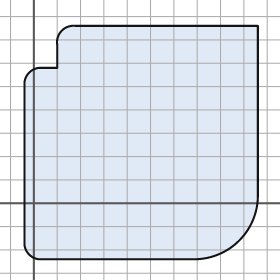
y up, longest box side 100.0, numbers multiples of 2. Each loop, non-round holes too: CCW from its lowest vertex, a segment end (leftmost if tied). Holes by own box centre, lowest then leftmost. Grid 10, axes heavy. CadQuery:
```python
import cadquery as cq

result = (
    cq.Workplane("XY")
    .moveTo(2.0, -24.0)
    .lineTo(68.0, -24.0)
    .threePointArc((88.0, -16.0), (96.0, 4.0))
    .lineTo(96.0, 76.0)
    .lineTo(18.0, 76.0)
    .threePointArc((12.0, 74.0), (10.0, 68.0))
    .lineTo(10.0, 58.0)
    .lineTo(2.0, 58.0)
    .threePointArc((-2.0, 56.0), (-4.0, 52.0))
    .lineTo(-4.0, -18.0)
    .threePointArc((-2.0, -22.0), (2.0, -24.0))
    .close()
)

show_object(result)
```